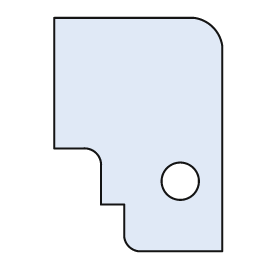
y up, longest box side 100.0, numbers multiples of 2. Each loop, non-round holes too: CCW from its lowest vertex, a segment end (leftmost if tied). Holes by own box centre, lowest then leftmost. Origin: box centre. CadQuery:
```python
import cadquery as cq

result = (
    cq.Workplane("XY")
    .moveTo(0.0, -50.0)
    .lineTo(36.0, -50.0)
    .lineTo(36.0, 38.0)
    .threePointArc((32.0, 46.0), (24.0, 50.0))
    .lineTo(-36.0, 50.0)
    .lineTo(-36.0, -6.0)
    .lineTo(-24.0, -6.0)
    .threePointArc((-18.0, -8.0), (-16.0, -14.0))
    .lineTo(-16.0, -30.0)
    .lineTo(-6.0, -30.0)
    .lineTo(-6.0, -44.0)
    .threePointArc((-4.0, -48.0), (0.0, -50.0))
    .close()
    .moveTo(18.0, -20.0)
    .circle(8.0)
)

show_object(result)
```